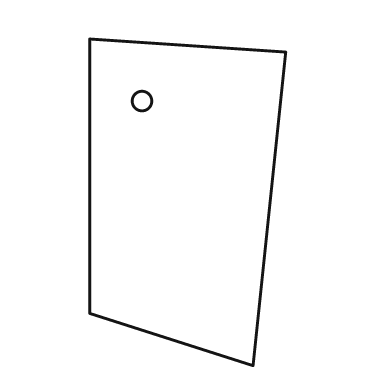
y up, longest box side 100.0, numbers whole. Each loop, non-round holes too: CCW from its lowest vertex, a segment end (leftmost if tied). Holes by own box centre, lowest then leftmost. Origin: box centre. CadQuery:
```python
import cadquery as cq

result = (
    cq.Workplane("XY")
    .moveTo(20.0, -50.0)
    .lineTo(30.0, 46.0)
    .lineTo(-30.0, 50.0)
    .lineTo(-30.0, -34.0)
    .close()
    .moveTo(-14.0, 31.0)
    .circle(3.0)
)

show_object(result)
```